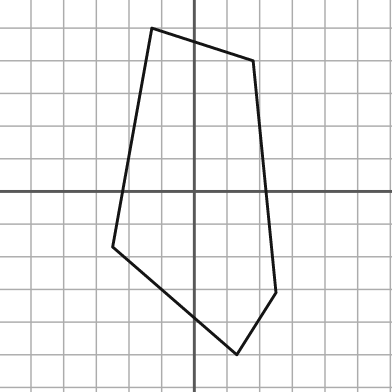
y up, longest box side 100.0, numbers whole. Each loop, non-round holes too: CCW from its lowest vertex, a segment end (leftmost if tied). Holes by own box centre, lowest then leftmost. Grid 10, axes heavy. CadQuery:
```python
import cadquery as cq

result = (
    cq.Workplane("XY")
    .moveTo(13.0, -50.0)
    .lineTo(25.0, -31.0)
    .lineTo(18.0, 40.0)
    .lineTo(-13.0, 50.0)
    .lineTo(-25.0, -17.0)
    .close()
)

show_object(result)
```